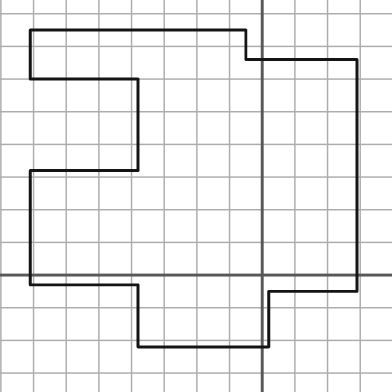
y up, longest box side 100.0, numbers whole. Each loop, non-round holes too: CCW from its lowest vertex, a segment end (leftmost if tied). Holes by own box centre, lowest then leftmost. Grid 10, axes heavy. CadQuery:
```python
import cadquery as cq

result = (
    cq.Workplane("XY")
    .moveTo(-38.0, -22.0)
    .lineTo(2.0, -22.0)
    .lineTo(2.0, -5.0)
    .lineTo(29.0, -5.0)
    .lineTo(29.0, 66.0)
    .lineTo(-5.0, 66.0)
    .lineTo(-5.0, 75.0)
    .lineTo(-71.0, 75.0)
    .lineTo(-71.0, 60.0)
    .lineTo(-38.0, 60.0)
    .lineTo(-38.0, 32.0)
    .lineTo(-71.0, 32.0)
    .lineTo(-71.0, -3.0)
    .lineTo(-38.0, -3.0)
    .close()
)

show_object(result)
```